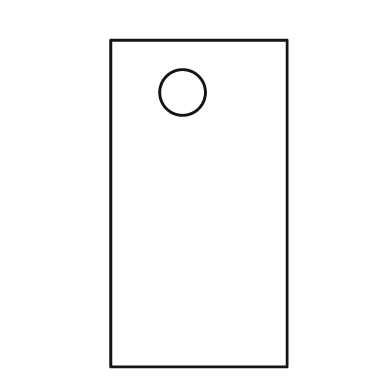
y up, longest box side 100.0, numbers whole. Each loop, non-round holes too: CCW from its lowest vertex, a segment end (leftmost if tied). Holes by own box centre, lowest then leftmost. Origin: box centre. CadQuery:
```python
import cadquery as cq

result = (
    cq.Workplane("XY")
    .moveTo(-27.0, -50.0)
    .lineTo(27.0, -50.0)
    .lineTo(27.0, 50.0)
    .lineTo(-27.0, 50.0)
    .close()
    .moveTo(-5.0, 34.0)
    .circle(7.0)
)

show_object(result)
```